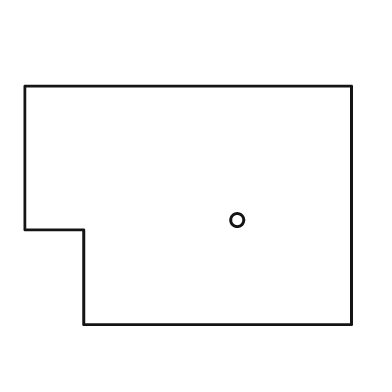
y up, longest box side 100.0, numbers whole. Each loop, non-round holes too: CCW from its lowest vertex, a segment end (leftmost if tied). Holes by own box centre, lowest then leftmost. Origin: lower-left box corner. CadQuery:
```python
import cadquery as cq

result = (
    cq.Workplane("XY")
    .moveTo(18.0, 0.0)
    .lineTo(100.0, 0.0)
    .lineTo(100.0, 73.0)
    .lineTo(0.0, 73.0)
    .lineTo(0.0, 29.0)
    .lineTo(18.0, 29.0)
    .close()
    .moveTo(65.0, 32.0)
    .circle(2.0)
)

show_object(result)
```